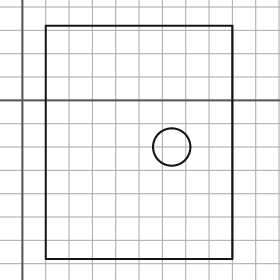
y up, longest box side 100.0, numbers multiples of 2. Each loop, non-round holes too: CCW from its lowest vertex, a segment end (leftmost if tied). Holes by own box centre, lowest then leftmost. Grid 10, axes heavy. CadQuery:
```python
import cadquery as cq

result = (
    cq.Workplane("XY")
    .moveTo(10.0, -68.0)
    .lineTo(90.0, -68.0)
    .lineTo(90.0, 32.0)
    .lineTo(10.0, 32.0)
    .close()
    .moveTo(64.0, -20.0)
    .circle(8.0)
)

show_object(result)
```